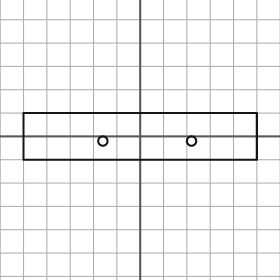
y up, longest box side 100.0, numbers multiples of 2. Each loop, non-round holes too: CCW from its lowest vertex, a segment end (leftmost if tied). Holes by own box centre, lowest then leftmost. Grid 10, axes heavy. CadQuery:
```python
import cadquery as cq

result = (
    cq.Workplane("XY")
    .moveTo(-50.0, -10.0)
    .lineTo(50.0, -10.0)
    .lineTo(50.0, 10.0)
    .lineTo(-50.0, 10.0)
    .close()
    .moveTo(-16.0, -2.0)
    .circle(2.0)
    .moveTo(22.0, -2.0)
    .circle(2.0)
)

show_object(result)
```